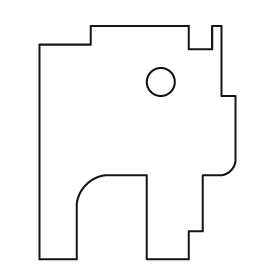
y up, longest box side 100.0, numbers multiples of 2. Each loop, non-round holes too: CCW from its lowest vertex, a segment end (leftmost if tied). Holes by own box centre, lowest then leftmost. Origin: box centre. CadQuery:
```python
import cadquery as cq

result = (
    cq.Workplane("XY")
    .moveTo(-42.0, -50.0)
    .lineTo(-26.0, -50.0)
    .lineTo(-26.0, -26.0)
    .threePointArc((-22.0, -18.0), (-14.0, -14.0))
    .lineTo(4.0, -14.0)
    .lineTo(4.0, -50.0)
    .lineTo(22.0, -50.0)
    .lineTo(22.0, -38.0)
    .lineTo(28.0, -38.0)
    .lineTo(28.0, -14.0)
    .lineTo(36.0, -14.0)
    .threePointArc((40.0, -12.0), (42.0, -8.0))
    .lineTo(42.0, 20.0)
    .lineTo(36.0, 20.0)
    .lineTo(36.0, 50.0)
    .lineTo(32.0, 50.0)
    .lineTo(32.0, 40.0)
    .lineTo(22.0, 40.0)
    .lineTo(22.0, 50.0)
    .lineTo(-20.0, 50.0)
    .lineTo(-20.0, 42.0)
    .lineTo(-42.0, 42.0)
    .close()
    .moveTo(10.0, 26.0)
    .circle(6.0)
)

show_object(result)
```